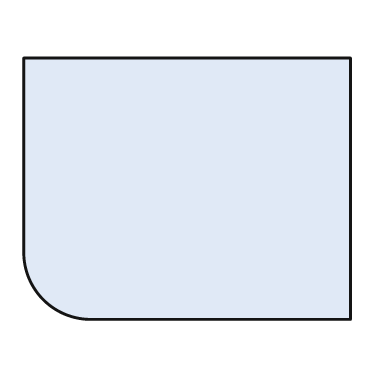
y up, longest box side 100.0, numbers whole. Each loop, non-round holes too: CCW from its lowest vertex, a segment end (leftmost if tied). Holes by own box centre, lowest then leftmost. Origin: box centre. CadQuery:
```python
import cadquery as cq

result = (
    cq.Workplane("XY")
    .moveTo(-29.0, -40.0)
    .lineTo(50.0, -40.0)
    .lineTo(50.0, 40.0)
    .lineTo(-50.0, 40.0)
    .lineTo(-50.0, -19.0)
    .threePointArc((-44.0, -34.0), (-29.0, -40.0))
    .close()
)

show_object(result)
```